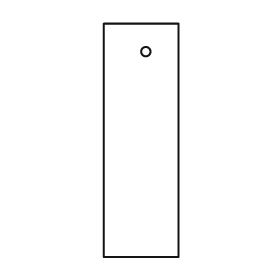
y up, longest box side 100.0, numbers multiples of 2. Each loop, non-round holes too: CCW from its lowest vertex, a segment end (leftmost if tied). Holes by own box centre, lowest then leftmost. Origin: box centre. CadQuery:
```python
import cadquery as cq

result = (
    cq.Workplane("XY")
    .moveTo(-16.0, -50.0)
    .lineTo(16.0, -50.0)
    .lineTo(16.0, 50.0)
    .lineTo(-16.0, 50.0)
    .close()
    .moveTo(2.0, 38.0)
    .circle(2.0)
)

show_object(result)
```